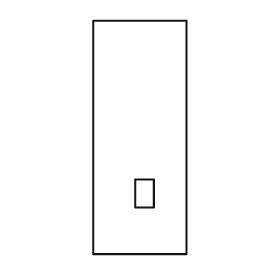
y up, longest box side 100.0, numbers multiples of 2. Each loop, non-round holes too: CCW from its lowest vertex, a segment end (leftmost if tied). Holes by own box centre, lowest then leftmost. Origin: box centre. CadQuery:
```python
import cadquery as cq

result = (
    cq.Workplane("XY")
    .moveTo(-20.0, -50.0)
    .lineTo(20.0, -50.0)
    .lineTo(20.0, 50.0)
    .lineTo(-20.0, 50.0)
    .close()
    .moveTo(-2.0, -30.0)
    .lineTo(6.0, -30.0)
    .lineTo(6.0, -18.0)
    .lineTo(-2.0, -18.0)
    .close()
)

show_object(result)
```